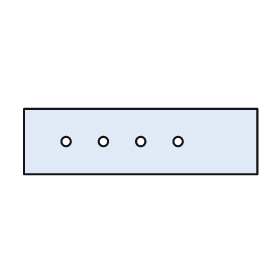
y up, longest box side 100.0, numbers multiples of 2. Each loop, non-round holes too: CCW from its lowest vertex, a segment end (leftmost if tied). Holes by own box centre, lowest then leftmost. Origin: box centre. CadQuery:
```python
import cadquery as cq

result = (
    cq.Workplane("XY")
    .moveTo(-50.0, -14.0)
    .lineTo(50.0, -14.0)
    .lineTo(50.0, 14.0)
    .lineTo(-50.0, 14.0)
    .close()
    .moveTo(-32.0, 0.0)
    .circle(2.0)
    .moveTo(-16.0, 0.0)
    .circle(2.0)
    .moveTo(0.0, 0.0)
    .circle(2.0)
    .moveTo(16.0, 0.0)
    .circle(2.0)
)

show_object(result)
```